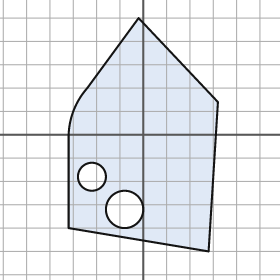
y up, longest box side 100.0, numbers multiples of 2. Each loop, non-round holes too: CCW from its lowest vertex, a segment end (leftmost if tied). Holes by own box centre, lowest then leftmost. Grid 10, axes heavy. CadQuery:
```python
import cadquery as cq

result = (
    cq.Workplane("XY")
    .moveTo(28.0, -50.0)
    .lineTo(32.0, 14.0)
    .lineTo(-2.0, 50.0)
    .lineTo(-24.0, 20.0)
    .threePointArc((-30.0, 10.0), (-32.0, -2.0))
    .lineTo(-32.0, -40.0)
    .close()
    .moveTo(-8.0, -32.0)
    .circle(8.0)
    .moveTo(-22.0, -18.0)
    .circle(6.0)
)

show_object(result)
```